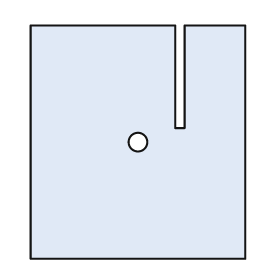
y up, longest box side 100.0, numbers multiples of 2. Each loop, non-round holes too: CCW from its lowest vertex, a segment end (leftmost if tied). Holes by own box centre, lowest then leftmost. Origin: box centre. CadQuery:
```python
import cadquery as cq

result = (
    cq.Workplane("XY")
    .moveTo(-46.0, -50.0)
    .lineTo(46.0, -50.0)
    .lineTo(46.0, 50.0)
    .lineTo(20.0, 50.0)
    .lineTo(20.0, 6.0)
    .lineTo(16.0, 6.0)
    .lineTo(16.0, 50.0)
    .lineTo(-46.0, 50.0)
    .close()
    .moveTo(0.0, 0.0)
    .circle(4.0)
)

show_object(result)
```